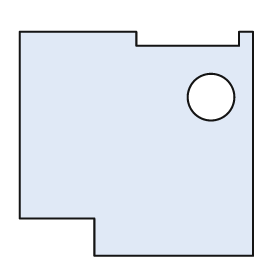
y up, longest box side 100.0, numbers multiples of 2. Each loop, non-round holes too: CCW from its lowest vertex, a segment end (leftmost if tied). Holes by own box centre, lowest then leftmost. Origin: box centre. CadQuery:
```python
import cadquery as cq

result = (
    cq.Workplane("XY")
    .moveTo(-18.0, -48.0)
    .lineTo(50.0, -48.0)
    .lineTo(50.0, 48.0)
    .lineTo(44.0, 48.0)
    .lineTo(44.0, 42.0)
    .lineTo(0.0, 42.0)
    .lineTo(0.0, 48.0)
    .lineTo(-50.0, 48.0)
    .lineTo(-50.0, -32.0)
    .lineTo(-18.0, -32.0)
    .close()
    .moveTo(32.0, 20.0)
    .circle(10.0)
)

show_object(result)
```